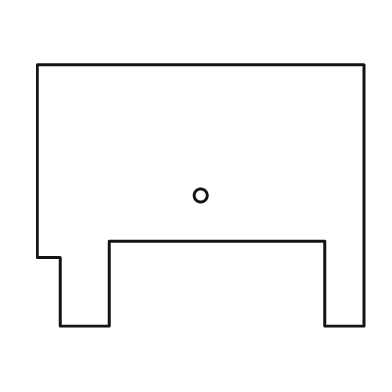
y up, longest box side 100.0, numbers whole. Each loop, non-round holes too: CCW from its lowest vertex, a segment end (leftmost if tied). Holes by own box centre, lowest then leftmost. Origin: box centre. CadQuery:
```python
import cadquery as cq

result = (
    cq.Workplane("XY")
    .moveTo(-43.0, -40.0)
    .lineTo(-28.0, -40.0)
    .lineTo(-28.0, -14.0)
    .lineTo(38.0, -14.0)
    .lineTo(38.0, -40.0)
    .lineTo(50.0, -40.0)
    .lineTo(50.0, 40.0)
    .lineTo(-50.0, 40.0)
    .lineTo(-50.0, -19.0)
    .lineTo(-43.0, -19.0)
    .close()
    .moveTo(0.0, 0.0)
    .circle(2.0)
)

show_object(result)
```